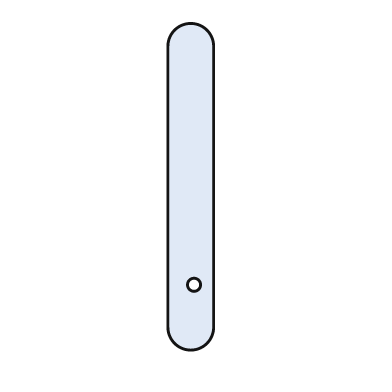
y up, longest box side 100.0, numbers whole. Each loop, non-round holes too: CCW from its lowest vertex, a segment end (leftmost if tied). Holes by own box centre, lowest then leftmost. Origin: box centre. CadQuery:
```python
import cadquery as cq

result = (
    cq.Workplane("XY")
    .moveTo(-7.0, -43.0)
    .threePointArc((0.0, -50.0), (7.0, -43.0))
    .lineTo(7.0, 43.0)
    .threePointArc((0.0, 50.0), (-7.0, 43.0))
    .close()
    .moveTo(1.0, -30.0)
    .circle(2.0)
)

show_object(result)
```